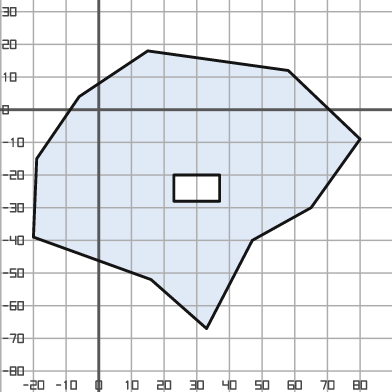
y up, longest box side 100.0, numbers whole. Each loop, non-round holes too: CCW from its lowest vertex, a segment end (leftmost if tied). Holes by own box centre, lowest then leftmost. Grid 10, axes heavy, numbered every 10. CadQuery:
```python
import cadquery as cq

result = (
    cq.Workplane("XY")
    .moveTo(33.0, -67.0)
    .lineTo(47.0, -40.0)
    .lineTo(65.0, -30.0)
    .lineTo(80.0, -9.0)
    .lineTo(58.0, 12.0)
    .lineTo(15.0, 18.0)
    .lineTo(-6.0, 4.0)
    .lineTo(-19.0, -15.0)
    .lineTo(-20.0, -39.0)
    .lineTo(16.0, -52.0)
    .close()
    .moveTo(23.0, -28.0)
    .lineTo(37.0, -28.0)
    .lineTo(37.0, -20.0)
    .lineTo(23.0, -20.0)
    .close()
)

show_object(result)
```